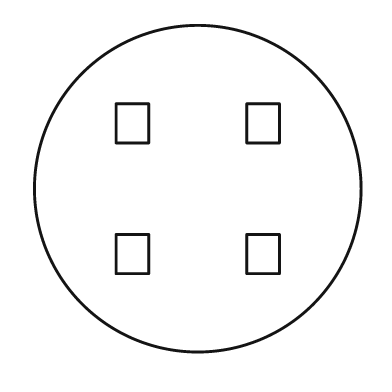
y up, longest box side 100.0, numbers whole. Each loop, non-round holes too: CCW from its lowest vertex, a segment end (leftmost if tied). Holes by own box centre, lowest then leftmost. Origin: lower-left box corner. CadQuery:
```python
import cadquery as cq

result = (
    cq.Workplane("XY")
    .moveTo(50.0, 50.0)
    .circle(50.0)
    .moveTo(25.0, 24.0)
    .lineTo(35.0, 24.0)
    .lineTo(35.0, 36.0)
    .lineTo(25.0, 36.0)
    .close()
    .moveTo(65.0, 24.0)
    .lineTo(75.0, 24.0)
    .lineTo(75.0, 36.0)
    .lineTo(65.0, 36.0)
    .close()
    .moveTo(25.0, 64.0)
    .lineTo(35.0, 64.0)
    .lineTo(35.0, 76.0)
    .lineTo(25.0, 76.0)
    .close()
    .moveTo(65.0, 64.0)
    .lineTo(75.0, 64.0)
    .lineTo(75.0, 76.0)
    .lineTo(65.0, 76.0)
    .close()
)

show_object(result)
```